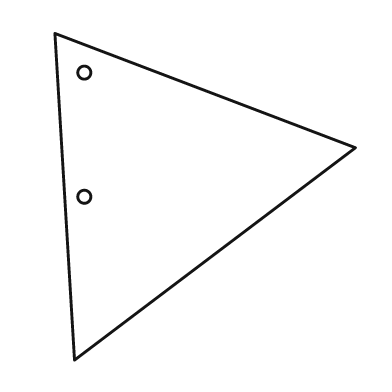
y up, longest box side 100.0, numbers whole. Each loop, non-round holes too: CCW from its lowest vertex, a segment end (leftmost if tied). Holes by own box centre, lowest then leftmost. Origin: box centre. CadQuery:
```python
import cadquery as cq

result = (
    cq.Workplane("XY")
    .moveTo(-40.0, -50.0)
    .lineTo(46.0, 15.0)
    .lineTo(-46.0, 50.0)
    .close()
    .moveTo(-37.0, 0.0)
    .circle(2.0)
    .moveTo(-37.0, 38.0)
    .circle(2.0)
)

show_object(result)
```